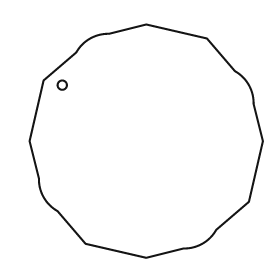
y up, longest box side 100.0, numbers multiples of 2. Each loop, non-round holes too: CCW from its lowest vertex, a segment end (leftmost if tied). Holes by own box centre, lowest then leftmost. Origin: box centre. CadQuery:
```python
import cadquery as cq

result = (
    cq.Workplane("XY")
    .moveTo(0.0, -50.0)
    .lineTo(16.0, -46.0)
    .threePointArc((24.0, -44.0), (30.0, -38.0))
    .lineTo(44.0, -26.0)
    .lineTo(50.0, 0.0)
    .lineTo(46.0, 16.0)
    .threePointArc((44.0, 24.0), (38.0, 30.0))
    .lineTo(26.0, 44.0)
    .lineTo(0.0, 50.0)
    .lineTo(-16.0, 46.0)
    .threePointArc((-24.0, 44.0), (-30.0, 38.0))
    .lineTo(-44.0, 26.0)
    .lineTo(-50.0, 0.0)
    .lineTo(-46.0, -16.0)
    .threePointArc((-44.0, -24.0), (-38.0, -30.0))
    .lineTo(-26.0, -44.0)
    .close()
    .moveTo(-36.0, 24.0)
    .circle(2.0)
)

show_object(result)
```